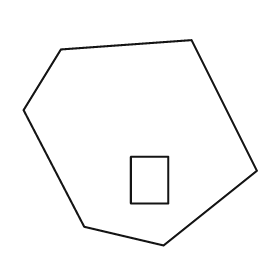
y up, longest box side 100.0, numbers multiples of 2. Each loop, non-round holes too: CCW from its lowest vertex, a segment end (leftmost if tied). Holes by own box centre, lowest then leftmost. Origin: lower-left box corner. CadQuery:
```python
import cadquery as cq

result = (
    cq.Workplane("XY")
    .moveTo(60.0, 0.0)
    .lineTo(100.0, 32.0)
    .lineTo(72.0, 88.0)
    .lineTo(16.0, 84.0)
    .lineTo(0.0, 58.0)
    .lineTo(26.0, 8.0)
    .close()
    .moveTo(46.0, 18.0)
    .lineTo(62.0, 18.0)
    .lineTo(62.0, 38.0)
    .lineTo(46.0, 38.0)
    .close()
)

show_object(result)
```